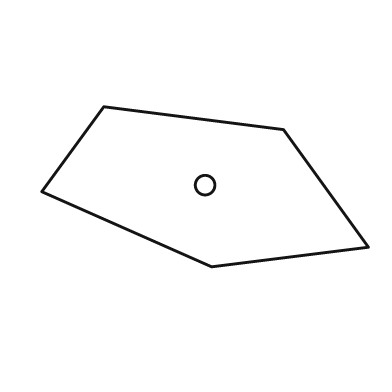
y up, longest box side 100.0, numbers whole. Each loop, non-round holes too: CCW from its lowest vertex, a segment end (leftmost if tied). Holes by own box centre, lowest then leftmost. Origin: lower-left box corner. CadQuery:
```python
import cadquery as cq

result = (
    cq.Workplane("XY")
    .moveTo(52.0, 0.0)
    .lineTo(100.0, 6.0)
    .lineTo(74.0, 42.0)
    .lineTo(19.0, 49.0)
    .lineTo(0.0, 23.0)
    .close()
    .moveTo(50.0, 25.0)
    .circle(3.0)
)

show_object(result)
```